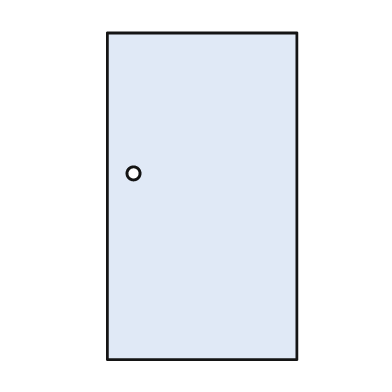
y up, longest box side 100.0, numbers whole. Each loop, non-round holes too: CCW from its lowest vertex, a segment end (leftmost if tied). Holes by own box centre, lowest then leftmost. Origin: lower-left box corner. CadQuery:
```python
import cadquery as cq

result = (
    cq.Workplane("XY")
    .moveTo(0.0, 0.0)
    .lineTo(58.0, 0.0)
    .lineTo(58.0, 100.0)
    .lineTo(0.0, 100.0)
    .close()
    .moveTo(8.0, 57.0)
    .circle(2.0)
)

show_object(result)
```